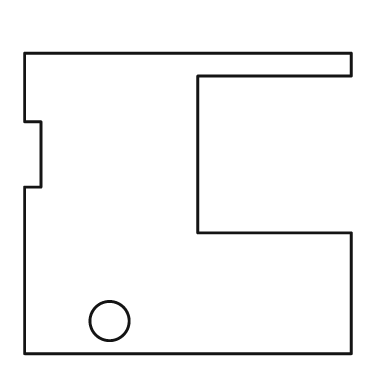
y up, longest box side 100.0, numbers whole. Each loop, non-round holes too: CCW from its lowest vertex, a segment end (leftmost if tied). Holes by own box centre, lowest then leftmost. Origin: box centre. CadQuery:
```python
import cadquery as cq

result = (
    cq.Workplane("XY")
    .moveTo(-50.0, -46.0)
    .lineTo(50.0, -46.0)
    .lineTo(50.0, -9.0)
    .lineTo(3.0, -9.0)
    .lineTo(3.0, 39.0)
    .lineTo(50.0, 39.0)
    .lineTo(50.0, 46.0)
    .lineTo(-50.0, 46.0)
    .lineTo(-50.0, 25.0)
    .lineTo(-45.0, 25.0)
    .lineTo(-45.0, 5.0)
    .lineTo(-50.0, 5.0)
    .close()
    .moveTo(-24.0, -36.0)
    .circle(6.0)
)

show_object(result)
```